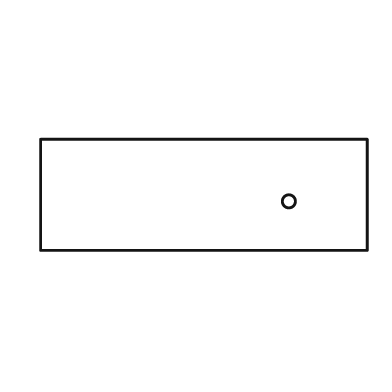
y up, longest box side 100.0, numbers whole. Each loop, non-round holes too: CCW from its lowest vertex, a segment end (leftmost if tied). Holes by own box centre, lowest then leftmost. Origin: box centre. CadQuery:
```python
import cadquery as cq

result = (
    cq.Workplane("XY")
    .moveTo(-50.0, -17.0)
    .lineTo(50.0, -17.0)
    .lineTo(50.0, 17.0)
    .lineTo(-50.0, 17.0)
    .close()
    .moveTo(26.0, -2.0)
    .circle(2.0)
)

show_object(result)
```